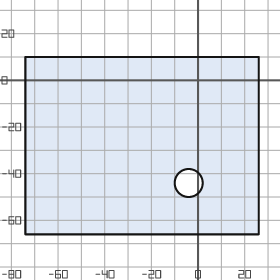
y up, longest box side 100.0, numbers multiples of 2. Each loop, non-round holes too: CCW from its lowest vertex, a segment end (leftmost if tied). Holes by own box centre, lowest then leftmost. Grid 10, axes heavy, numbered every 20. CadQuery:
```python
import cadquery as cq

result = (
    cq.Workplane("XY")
    .moveTo(-74.0, -66.0)
    .lineTo(26.0, -66.0)
    .lineTo(26.0, 10.0)
    .lineTo(-74.0, 10.0)
    .close()
    .moveTo(-4.0, -44.0)
    .circle(6.0)
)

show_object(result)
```